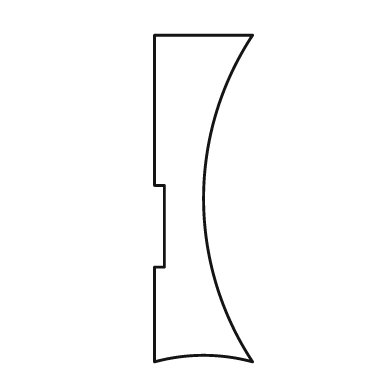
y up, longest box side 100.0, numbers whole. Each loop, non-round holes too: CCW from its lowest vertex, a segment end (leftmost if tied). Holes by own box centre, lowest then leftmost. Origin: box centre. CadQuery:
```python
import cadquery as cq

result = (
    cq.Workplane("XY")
    .moveTo(-15.0, -50.0)
    .threePointArc((0.0, -48.0), (15.0, -50.0))
    .threePointArc((0.0, 0.0), (15.0, 50.0))
    .lineTo(-15.0, 50.0)
    .lineTo(-15.0, 4.0)
    .lineTo(-12.0, 4.0)
    .lineTo(-12.0, -21.0)
    .lineTo(-15.0, -21.0)
    .close()
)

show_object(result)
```